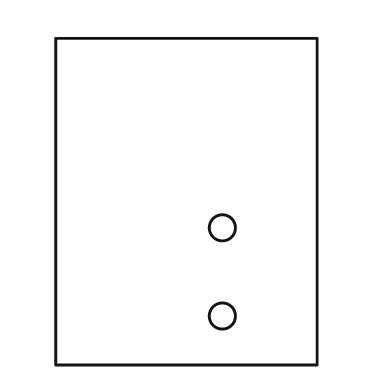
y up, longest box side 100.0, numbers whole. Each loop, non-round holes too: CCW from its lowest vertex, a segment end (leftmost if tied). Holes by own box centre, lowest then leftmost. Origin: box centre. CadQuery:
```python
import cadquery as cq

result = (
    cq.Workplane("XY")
    .moveTo(-40.0, -50.0)
    .lineTo(40.0, -50.0)
    .lineTo(40.0, 50.0)
    .lineTo(-40.0, 50.0)
    .close()
    .moveTo(11.0, -35.0)
    .circle(4.0)
    .moveTo(11.0, -8.0)
    .circle(4.0)
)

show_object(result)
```